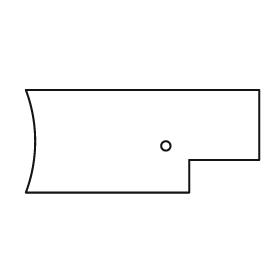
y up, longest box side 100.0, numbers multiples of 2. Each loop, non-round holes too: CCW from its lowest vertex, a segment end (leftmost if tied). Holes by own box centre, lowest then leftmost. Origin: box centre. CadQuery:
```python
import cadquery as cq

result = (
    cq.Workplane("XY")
    .moveTo(-50.0, -22.0)
    .lineTo(20.0, -22.0)
    .lineTo(20.0, -8.0)
    .lineTo(50.0, -8.0)
    .lineTo(50.0, 22.0)
    .lineTo(-50.0, 22.0)
    .threePointArc((-46.0, 0.0), (-50.0, -22.0))
    .close()
    .moveTo(10.0, -2.0)
    .circle(2.0)
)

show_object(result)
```